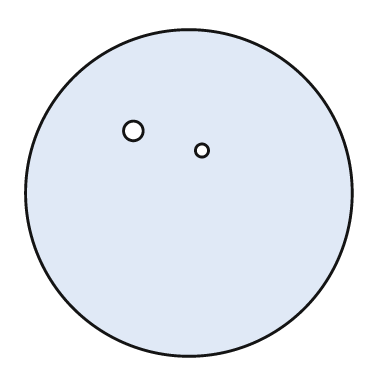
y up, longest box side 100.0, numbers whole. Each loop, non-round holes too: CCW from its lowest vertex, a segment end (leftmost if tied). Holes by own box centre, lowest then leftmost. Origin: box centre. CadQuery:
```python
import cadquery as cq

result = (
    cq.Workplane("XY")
    .moveTo(0.0, 0.0)
    .circle(50.0)
    .moveTo(4.0, 13.0)
    .circle(2.0)
    .moveTo(-17.0, 19.0)
    .circle(3.0)
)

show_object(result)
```